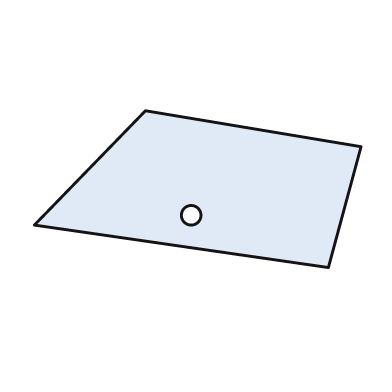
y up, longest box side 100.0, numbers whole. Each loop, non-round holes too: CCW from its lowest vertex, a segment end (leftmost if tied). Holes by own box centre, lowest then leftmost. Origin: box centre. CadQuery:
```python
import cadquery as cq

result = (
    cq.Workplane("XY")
    .moveTo(40.0, -24.0)
    .lineTo(50.0, 13.0)
    .lineTo(-16.0, 24.0)
    .lineTo(-50.0, -11.0)
    .close()
    .moveTo(-2.0, -8.0)
    .circle(3.0)
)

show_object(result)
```